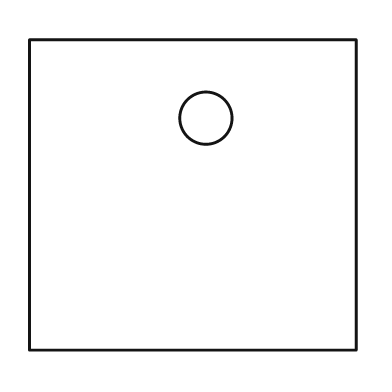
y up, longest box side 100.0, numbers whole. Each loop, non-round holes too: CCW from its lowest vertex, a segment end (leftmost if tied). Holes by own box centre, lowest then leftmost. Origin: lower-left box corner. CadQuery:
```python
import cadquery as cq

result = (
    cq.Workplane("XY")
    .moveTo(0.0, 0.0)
    .lineTo(100.0, 0.0)
    .lineTo(100.0, 95.0)
    .lineTo(0.0, 95.0)
    .close()
    .moveTo(54.0, 71.0)
    .circle(8.0)
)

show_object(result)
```